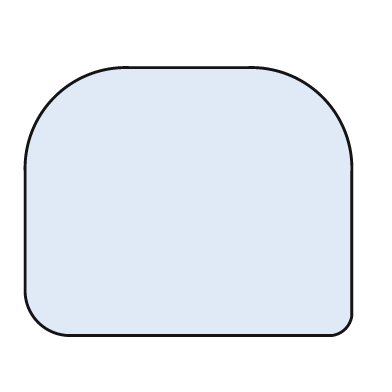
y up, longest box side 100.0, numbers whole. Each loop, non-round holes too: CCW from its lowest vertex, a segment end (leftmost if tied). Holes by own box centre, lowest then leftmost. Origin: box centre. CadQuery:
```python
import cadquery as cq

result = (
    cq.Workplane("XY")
    .moveTo(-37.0, -41.0)
    .lineTo(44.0, -41.0)
    .threePointArc((48.0, -39.0), (50.0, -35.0))
    .lineTo(50.0, 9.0)
    .threePointArc((41.0, 32.0), (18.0, 41.0))
    .lineTo(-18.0, 41.0)
    .threePointArc((-41.0, 32.0), (-50.0, 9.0))
    .lineTo(-50.0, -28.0)
    .threePointArc((-46.0, -37.0), (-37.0, -41.0))
    .close()
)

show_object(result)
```